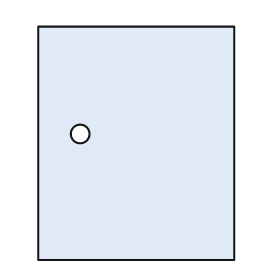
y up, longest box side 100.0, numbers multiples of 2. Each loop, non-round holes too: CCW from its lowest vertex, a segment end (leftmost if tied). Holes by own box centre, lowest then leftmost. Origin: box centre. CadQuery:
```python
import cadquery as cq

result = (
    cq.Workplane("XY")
    .moveTo(-42.0, -50.0)
    .lineTo(42.0, -50.0)
    .lineTo(42.0, 50.0)
    .lineTo(-42.0, 50.0)
    .close()
    .moveTo(-24.0, 4.0)
    .circle(4.0)
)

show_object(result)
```